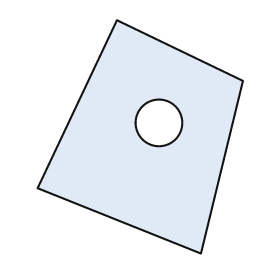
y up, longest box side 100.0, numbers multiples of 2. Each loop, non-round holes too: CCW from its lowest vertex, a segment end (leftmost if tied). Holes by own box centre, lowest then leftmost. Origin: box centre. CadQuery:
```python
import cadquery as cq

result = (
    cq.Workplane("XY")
    .moveTo(26.0, -50.0)
    .lineTo(44.0, 24.0)
    .lineTo(-10.0, 50.0)
    .lineTo(-44.0, -22.0)
    .close()
    .moveTo(8.0, 6.0)
    .circle(10.0)
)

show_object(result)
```